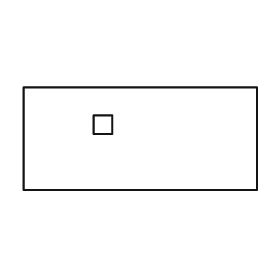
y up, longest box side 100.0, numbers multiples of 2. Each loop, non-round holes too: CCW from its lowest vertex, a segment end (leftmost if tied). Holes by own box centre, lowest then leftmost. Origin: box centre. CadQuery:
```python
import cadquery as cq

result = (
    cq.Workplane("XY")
    .moveTo(-50.0, -22.0)
    .lineTo(50.0, -22.0)
    .lineTo(50.0, 22.0)
    .lineTo(-50.0, 22.0)
    .close()
    .moveTo(-20.0, 2.0)
    .lineTo(-12.0, 2.0)
    .lineTo(-12.0, 10.0)
    .lineTo(-20.0, 10.0)
    .close()
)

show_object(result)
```